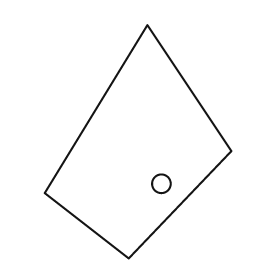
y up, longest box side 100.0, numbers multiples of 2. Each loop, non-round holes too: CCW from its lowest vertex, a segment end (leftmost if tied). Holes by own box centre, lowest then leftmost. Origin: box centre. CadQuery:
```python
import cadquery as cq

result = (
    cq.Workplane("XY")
    .moveTo(-4.0, -50.0)
    .lineTo(40.0, -4.0)
    .lineTo(4.0, 50.0)
    .lineTo(-40.0, -22.0)
    .close()
    .moveTo(10.0, -18.0)
    .circle(4.0)
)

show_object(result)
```